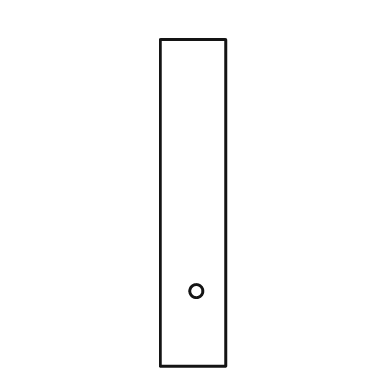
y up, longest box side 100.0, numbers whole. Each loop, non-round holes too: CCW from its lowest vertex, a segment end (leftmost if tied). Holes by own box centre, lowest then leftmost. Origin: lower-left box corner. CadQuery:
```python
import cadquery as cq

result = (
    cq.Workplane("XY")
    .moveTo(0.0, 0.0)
    .lineTo(20.0, 0.0)
    .lineTo(20.0, 100.0)
    .lineTo(0.0, 100.0)
    .close()
    .moveTo(11.0, 23.0)
    .circle(2.0)
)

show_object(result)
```